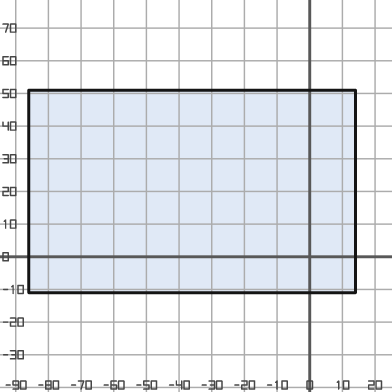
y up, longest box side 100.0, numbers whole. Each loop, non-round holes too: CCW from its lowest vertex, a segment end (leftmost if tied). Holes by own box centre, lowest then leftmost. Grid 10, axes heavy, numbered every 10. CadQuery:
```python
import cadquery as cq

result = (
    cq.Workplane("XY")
    .moveTo(-86.0, -11.0)
    .lineTo(14.0, -11.0)
    .lineTo(14.0, 51.0)
    .lineTo(-86.0, 51.0)
    .close()
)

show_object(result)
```